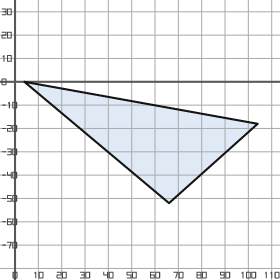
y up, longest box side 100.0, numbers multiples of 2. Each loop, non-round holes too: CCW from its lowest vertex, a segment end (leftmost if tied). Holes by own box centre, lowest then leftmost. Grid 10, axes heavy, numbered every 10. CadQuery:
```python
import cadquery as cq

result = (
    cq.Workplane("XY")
    .moveTo(66.0, -52.0)
    .lineTo(104.0, -18.0)
    .lineTo(4.0, 0.0)
    .close()
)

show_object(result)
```